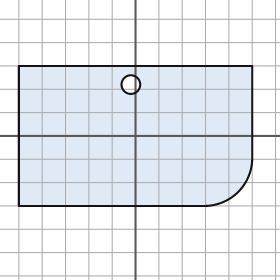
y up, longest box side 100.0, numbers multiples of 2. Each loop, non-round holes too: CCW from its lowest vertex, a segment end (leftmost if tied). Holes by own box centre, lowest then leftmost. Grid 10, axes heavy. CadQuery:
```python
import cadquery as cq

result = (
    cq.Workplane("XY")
    .moveTo(-50.0, -30.0)
    .lineTo(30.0, -30.0)
    .threePointArc((44.0, -24.0), (50.0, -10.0))
    .lineTo(50.0, 30.0)
    .lineTo(-50.0, 30.0)
    .close()
    .moveTo(-2.0, 22.0)
    .circle(4.0)
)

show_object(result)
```